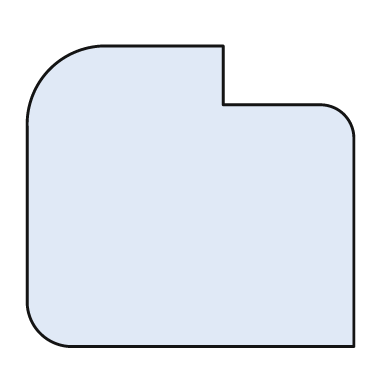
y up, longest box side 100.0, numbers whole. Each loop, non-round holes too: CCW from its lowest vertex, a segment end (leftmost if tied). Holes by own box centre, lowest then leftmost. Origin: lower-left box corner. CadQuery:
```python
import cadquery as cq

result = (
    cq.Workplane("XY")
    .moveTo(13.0, 0.0)
    .lineTo(100.0, 0.0)
    .lineTo(100.0, 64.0)
    .threePointArc((97.0, 71.0), (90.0, 74.0))
    .lineTo(60.0, 74.0)
    .lineTo(60.0, 92.0)
    .lineTo(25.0, 92.0)
    .threePointArc((7.0, 85.0), (0.0, 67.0))
    .lineTo(0.0, 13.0)
    .threePointArc((4.0, 4.0), (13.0, 0.0))
    .close()
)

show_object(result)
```